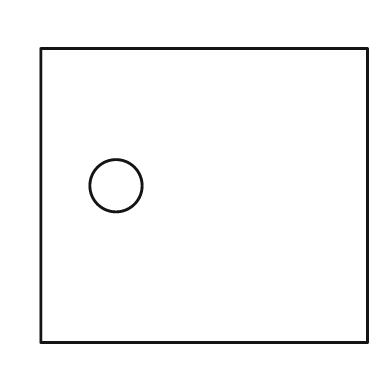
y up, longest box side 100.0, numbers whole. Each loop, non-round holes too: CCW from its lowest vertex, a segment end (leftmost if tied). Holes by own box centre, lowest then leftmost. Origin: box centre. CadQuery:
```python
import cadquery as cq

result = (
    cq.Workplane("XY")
    .moveTo(-50.0, -45.0)
    .lineTo(50.0, -45.0)
    .lineTo(50.0, 45.0)
    .lineTo(-50.0, 45.0)
    .close()
    .moveTo(-27.0, 3.0)
    .circle(8.0)
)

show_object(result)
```